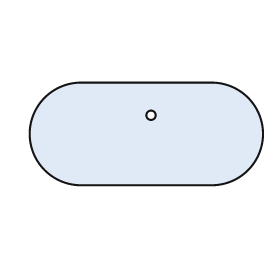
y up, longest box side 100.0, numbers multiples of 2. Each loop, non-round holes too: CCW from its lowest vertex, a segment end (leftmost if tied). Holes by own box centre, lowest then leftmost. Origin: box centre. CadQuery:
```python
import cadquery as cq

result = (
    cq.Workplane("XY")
    .moveTo(-28.0, -22.0)
    .lineTo(28.0, -22.0)
    .threePointArc((50.0, 0.0), (28.0, 22.0))
    .lineTo(-28.0, 22.0)
    .threePointArc((-50.0, 0.0), (-28.0, -22.0))
    .close()
    .moveTo(2.0, 8.0)
    .circle(2.0)
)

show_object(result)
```